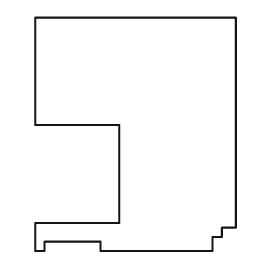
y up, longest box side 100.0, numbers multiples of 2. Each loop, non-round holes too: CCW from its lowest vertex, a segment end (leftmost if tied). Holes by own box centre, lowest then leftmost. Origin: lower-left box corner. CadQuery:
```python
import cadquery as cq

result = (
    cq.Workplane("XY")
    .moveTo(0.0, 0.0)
    .lineTo(4.0, 0.0)
    .lineTo(4.0, 4.0)
    .lineTo(28.0, 4.0)
    .lineTo(28.0, 0.0)
    .lineTo(76.0, 0.0)
    .lineTo(76.0, 6.0)
    .lineTo(80.0, 6.0)
    .lineTo(80.0, 10.0)
    .lineTo(86.0, 10.0)
    .lineTo(86.0, 100.0)
    .lineTo(0.0, 100.0)
    .lineTo(0.0, 54.0)
    .lineTo(36.0, 54.0)
    .lineTo(36.0, 12.0)
    .lineTo(0.0, 12.0)
    .close()
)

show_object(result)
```